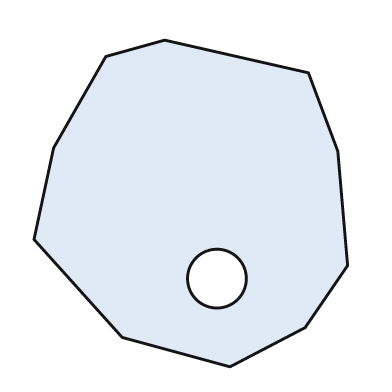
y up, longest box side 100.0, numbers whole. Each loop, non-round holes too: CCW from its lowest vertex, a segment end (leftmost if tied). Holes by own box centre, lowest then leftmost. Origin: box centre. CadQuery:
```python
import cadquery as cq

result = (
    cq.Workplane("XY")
    .moveTo(12.0, -50.0)
    .lineTo(35.0, -38.0)
    .lineTo(48.0, -19.0)
    .lineTo(45.0, 16.0)
    .lineTo(36.0, 40.0)
    .lineTo(-8.0, 50.0)
    .lineTo(-26.0, 45.0)
    .lineTo(-42.0, 17.0)
    .lineTo(-48.0, -11.0)
    .lineTo(-21.0, -41.0)
    .close()
    .moveTo(8.0, -23.0)
    .circle(9.0)
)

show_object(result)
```